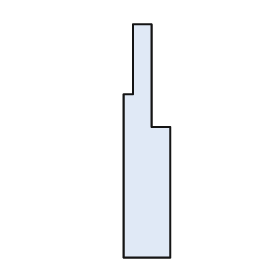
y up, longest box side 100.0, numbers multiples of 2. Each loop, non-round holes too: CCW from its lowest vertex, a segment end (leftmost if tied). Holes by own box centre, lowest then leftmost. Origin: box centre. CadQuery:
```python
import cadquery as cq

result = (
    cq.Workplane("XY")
    .moveTo(-10.0, -50.0)
    .lineTo(10.0, -50.0)
    .lineTo(10.0, 6.0)
    .lineTo(2.0, 6.0)
    .lineTo(2.0, 50.0)
    .lineTo(-6.0, 50.0)
    .lineTo(-6.0, 20.0)
    .lineTo(-10.0, 20.0)
    .close()
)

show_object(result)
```